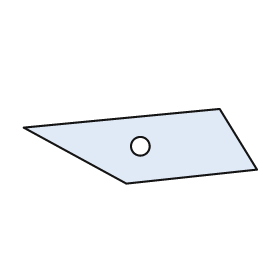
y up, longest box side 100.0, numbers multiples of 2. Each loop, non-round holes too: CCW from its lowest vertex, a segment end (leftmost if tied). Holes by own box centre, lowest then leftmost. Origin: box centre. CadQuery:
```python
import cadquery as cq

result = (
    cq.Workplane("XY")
    .moveTo(-6.0, -16.0)
    .lineTo(50.0, -10.0)
    .lineTo(34.0, 16.0)
    .lineTo(-50.0, 8.0)
    .close()
    .moveTo(0.0, 0.0)
    .circle(4.0)
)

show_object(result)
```